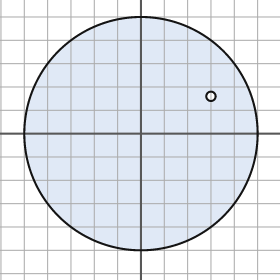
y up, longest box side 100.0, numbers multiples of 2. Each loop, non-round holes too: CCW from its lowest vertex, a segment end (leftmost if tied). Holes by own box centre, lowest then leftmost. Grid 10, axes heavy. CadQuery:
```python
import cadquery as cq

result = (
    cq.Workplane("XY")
    .moveTo(0.0, 0.0)
    .circle(50.0)
    .moveTo(30.0, 16.0)
    .circle(2.0)
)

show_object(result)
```